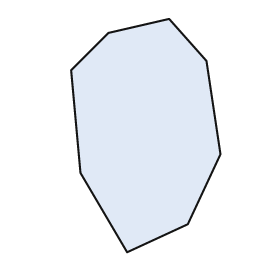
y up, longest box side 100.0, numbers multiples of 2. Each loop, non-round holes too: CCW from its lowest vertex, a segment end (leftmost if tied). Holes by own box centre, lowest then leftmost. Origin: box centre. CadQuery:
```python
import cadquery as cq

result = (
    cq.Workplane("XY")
    .moveTo(-8.0, -50.0)
    .lineTo(18.0, -38.0)
    .lineTo(32.0, -8.0)
    .lineTo(26.0, 32.0)
    .lineTo(10.0, 50.0)
    .lineTo(-16.0, 44.0)
    .lineTo(-32.0, 28.0)
    .lineTo(-28.0, -16.0)
    .close()
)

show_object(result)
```